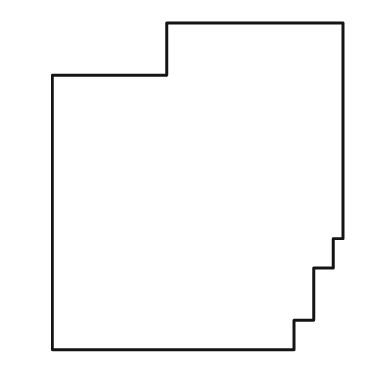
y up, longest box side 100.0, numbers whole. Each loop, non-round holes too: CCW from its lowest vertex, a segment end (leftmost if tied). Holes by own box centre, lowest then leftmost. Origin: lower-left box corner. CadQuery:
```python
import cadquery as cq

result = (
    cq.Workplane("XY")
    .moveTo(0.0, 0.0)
    .lineTo(74.0, 0.0)
    .lineTo(74.0, 9.0)
    .lineTo(80.0, 9.0)
    .lineTo(80.0, 25.0)
    .lineTo(86.0, 25.0)
    .lineTo(86.0, 34.0)
    .lineTo(89.0, 34.0)
    .lineTo(89.0, 100.0)
    .lineTo(35.0, 100.0)
    .lineTo(35.0, 84.0)
    .lineTo(0.0, 84.0)
    .close()
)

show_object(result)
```